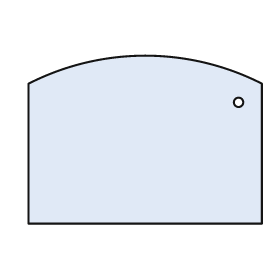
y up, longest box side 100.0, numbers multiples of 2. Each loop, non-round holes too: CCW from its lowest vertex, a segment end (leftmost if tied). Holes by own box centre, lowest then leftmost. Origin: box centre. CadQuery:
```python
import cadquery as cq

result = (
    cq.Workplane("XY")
    .moveTo(-50.0, -36.0)
    .lineTo(50.0, -36.0)
    .lineTo(50.0, 24.0)
    .threePointArc((0.0, 36.0), (-50.0, 24.0))
    .close()
    .moveTo(40.0, 16.0)
    .circle(2.0)
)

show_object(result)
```